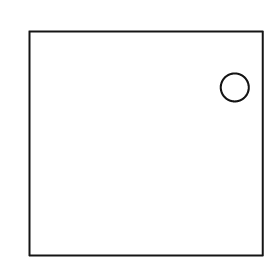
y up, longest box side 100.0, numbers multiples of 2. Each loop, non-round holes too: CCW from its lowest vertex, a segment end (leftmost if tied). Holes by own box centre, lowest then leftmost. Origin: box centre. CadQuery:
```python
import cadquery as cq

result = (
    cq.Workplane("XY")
    .moveTo(-50.0, -48.0)
    .lineTo(50.0, -48.0)
    .lineTo(50.0, 48.0)
    .lineTo(-50.0, 48.0)
    .close()
    .moveTo(38.0, 24.0)
    .circle(6.0)
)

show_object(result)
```